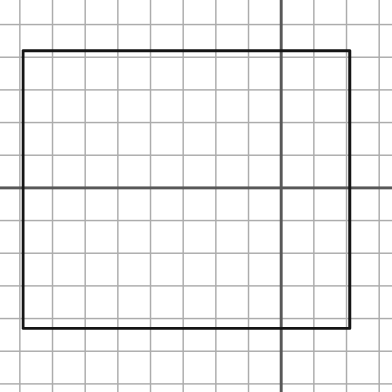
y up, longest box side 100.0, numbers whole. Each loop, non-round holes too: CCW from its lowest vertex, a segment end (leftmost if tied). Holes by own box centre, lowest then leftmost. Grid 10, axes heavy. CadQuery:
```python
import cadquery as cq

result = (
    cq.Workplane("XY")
    .moveTo(-79.0, -43.0)
    .lineTo(21.0, -43.0)
    .lineTo(21.0, 42.0)
    .lineTo(-79.0, 42.0)
    .close()
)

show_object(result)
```